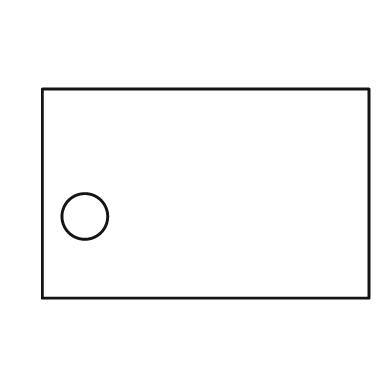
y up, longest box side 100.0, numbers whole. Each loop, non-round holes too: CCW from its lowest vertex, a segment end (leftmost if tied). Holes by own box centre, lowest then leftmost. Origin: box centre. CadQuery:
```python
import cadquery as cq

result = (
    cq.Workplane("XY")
    .moveTo(-50.0, -32.0)
    .lineTo(50.0, -32.0)
    .lineTo(50.0, 32.0)
    .lineTo(-50.0, 32.0)
    .close()
    .moveTo(-37.0, -7.0)
    .circle(7.0)
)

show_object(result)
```